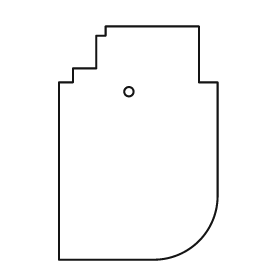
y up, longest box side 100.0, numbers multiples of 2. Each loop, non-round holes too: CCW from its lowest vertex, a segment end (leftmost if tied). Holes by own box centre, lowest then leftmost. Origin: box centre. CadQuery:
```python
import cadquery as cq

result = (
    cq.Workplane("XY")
    .moveTo(-34.0, -50.0)
    .lineTo(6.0, -50.0)
    .threePointArc((26.0, -42.0), (34.0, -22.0))
    .lineTo(34.0, 26.0)
    .lineTo(26.0, 26.0)
    .lineTo(26.0, 50.0)
    .lineTo(-14.0, 50.0)
    .lineTo(-14.0, 46.0)
    .lineTo(-18.0, 46.0)
    .lineTo(-18.0, 32.0)
    .lineTo(-28.0, 32.0)
    .lineTo(-28.0, 26.0)
    .lineTo(-34.0, 26.0)
    .close()
    .moveTo(-4.0, 22.0)
    .circle(2.0)
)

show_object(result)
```